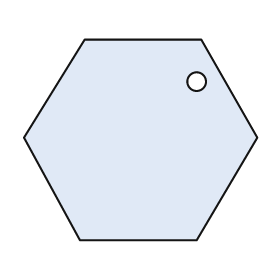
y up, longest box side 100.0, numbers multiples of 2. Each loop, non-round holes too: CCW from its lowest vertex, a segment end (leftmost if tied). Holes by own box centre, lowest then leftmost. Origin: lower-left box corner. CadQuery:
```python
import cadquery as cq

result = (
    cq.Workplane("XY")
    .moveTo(24.0, 0.0)
    .lineTo(74.0, 0.0)
    .lineTo(100.0, 44.0)
    .lineTo(76.0, 86.0)
    .lineTo(26.0, 86.0)
    .lineTo(0.0, 44.0)
    .close()
    .moveTo(74.0, 68.0)
    .circle(4.0)
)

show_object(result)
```